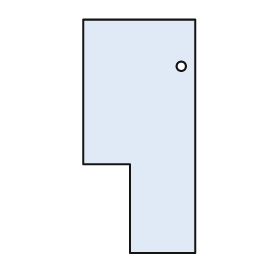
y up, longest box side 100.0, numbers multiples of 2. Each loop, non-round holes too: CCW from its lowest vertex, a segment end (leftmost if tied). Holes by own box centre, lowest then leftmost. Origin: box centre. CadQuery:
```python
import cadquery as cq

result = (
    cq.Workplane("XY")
    .moveTo(-4.0, -50.0)
    .lineTo(24.0, -50.0)
    .lineTo(24.0, 50.0)
    .lineTo(-24.0, 50.0)
    .lineTo(-24.0, -12.0)
    .lineTo(-4.0, -12.0)
    .close()
    .moveTo(18.0, 30.0)
    .circle(2.0)
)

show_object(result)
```